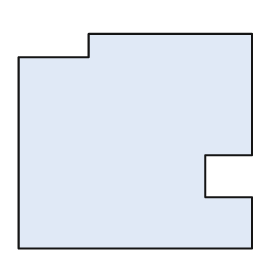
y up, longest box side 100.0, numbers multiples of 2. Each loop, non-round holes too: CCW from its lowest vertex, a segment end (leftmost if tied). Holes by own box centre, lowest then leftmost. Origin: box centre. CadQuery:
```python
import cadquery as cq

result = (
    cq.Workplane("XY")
    .moveTo(-50.0, -46.0)
    .lineTo(50.0, -46.0)
    .lineTo(50.0, -24.0)
    .lineTo(30.0, -24.0)
    .lineTo(30.0, -6.0)
    .lineTo(50.0, -6.0)
    .lineTo(50.0, 46.0)
    .lineTo(-20.0, 46.0)
    .lineTo(-20.0, 36.0)
    .lineTo(-50.0, 36.0)
    .close()
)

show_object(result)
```